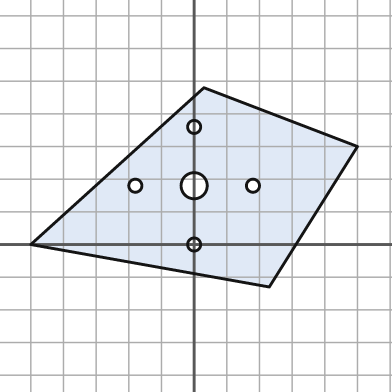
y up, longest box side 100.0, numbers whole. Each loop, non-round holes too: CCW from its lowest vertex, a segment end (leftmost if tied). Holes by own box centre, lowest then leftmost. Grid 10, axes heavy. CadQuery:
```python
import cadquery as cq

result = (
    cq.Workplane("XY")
    .moveTo(23.0, -13.0)
    .lineTo(50.0, 30.0)
    .lineTo(3.0, 48.0)
    .lineTo(-50.0, 0.0)
    .close()
    .moveTo(0.0, 0.0)
    .circle(2.0)
    .moveTo(-18.0, 18.0)
    .circle(2.0)
    .moveTo(0.0, 18.0)
    .circle(4.0)
    .moveTo(18.0, 18.0)
    .circle(2.0)
    .moveTo(0.0, 36.0)
    .circle(2.0)
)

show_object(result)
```